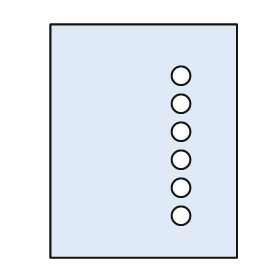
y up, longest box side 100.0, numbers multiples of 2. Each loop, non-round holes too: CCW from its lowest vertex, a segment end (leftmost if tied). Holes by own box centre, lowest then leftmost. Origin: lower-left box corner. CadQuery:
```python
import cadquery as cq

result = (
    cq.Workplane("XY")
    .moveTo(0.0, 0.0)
    .lineTo(80.0, 0.0)
    .lineTo(80.0, 100.0)
    .lineTo(0.0, 100.0)
    .close()
    .moveTo(56.0, 18.0)
    .circle(4.0)
    .moveTo(56.0, 30.0)
    .circle(4.0)
    .moveTo(56.0, 42.0)
    .circle(4.0)
    .moveTo(56.0, 54.0)
    .circle(4.0)
    .moveTo(56.0, 66.0)
    .circle(4.0)
    .moveTo(56.0, 78.0)
    .circle(4.0)
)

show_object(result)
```